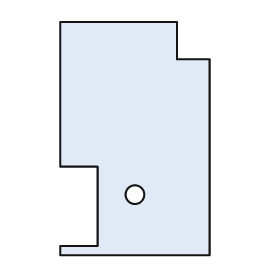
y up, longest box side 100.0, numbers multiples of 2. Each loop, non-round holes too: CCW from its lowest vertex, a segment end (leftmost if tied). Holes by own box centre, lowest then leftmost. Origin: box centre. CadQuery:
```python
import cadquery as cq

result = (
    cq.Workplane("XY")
    .moveTo(-32.0, -50.0)
    .lineTo(32.0, -50.0)
    .lineTo(32.0, 34.0)
    .lineTo(18.0, 34.0)
    .lineTo(18.0, 50.0)
    .lineTo(-32.0, 50.0)
    .lineTo(-32.0, -12.0)
    .lineTo(-16.0, -12.0)
    .lineTo(-16.0, -46.0)
    .lineTo(-32.0, -46.0)
    .close()
    .moveTo(0.0, -24.0)
    .circle(4.0)
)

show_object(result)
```